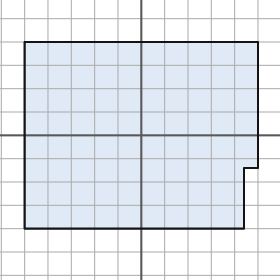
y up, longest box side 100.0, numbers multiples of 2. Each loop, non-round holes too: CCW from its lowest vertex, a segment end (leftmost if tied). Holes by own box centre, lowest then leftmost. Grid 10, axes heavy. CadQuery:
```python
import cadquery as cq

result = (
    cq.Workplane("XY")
    .moveTo(-50.0, -40.0)
    .lineTo(44.0, -40.0)
    .lineTo(44.0, -14.0)
    .lineTo(50.0, -14.0)
    .lineTo(50.0, 40.0)
    .lineTo(-50.0, 40.0)
    .close()
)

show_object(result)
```